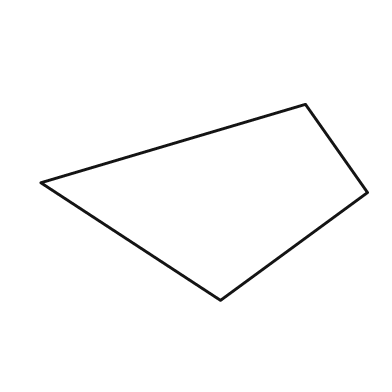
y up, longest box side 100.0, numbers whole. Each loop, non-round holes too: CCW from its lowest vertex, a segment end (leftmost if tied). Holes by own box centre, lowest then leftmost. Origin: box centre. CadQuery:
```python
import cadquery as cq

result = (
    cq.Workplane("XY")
    .moveTo(5.0, -30.0)
    .lineTo(50.0, 3.0)
    .lineTo(31.0, 30.0)
    .lineTo(-50.0, 6.0)
    .close()
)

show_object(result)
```